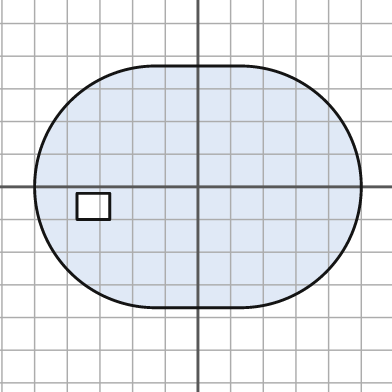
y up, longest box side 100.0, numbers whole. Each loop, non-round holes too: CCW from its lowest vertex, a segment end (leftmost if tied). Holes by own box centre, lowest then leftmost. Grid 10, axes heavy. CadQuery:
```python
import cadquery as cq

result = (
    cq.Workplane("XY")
    .moveTo(-13.0, -37.0)
    .lineTo(13.0, -37.0)
    .threePointArc((50.0, 0.0), (13.0, 37.0))
    .lineTo(-13.0, 37.0)
    .threePointArc((-50.0, 0.0), (-13.0, -37.0))
    .close()
    .moveTo(-37.0, -10.0)
    .lineTo(-27.0, -10.0)
    .lineTo(-27.0, -2.0)
    .lineTo(-37.0, -2.0)
    .close()
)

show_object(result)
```